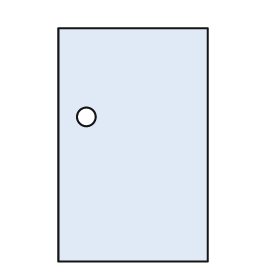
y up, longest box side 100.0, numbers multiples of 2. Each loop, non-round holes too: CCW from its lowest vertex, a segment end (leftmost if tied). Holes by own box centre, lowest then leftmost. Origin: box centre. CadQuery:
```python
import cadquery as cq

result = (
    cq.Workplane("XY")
    .moveTo(-32.0, -50.0)
    .lineTo(32.0, -50.0)
    .lineTo(32.0, 50.0)
    .lineTo(-32.0, 50.0)
    .close()
    .moveTo(-20.0, 12.0)
    .circle(4.0)
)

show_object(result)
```